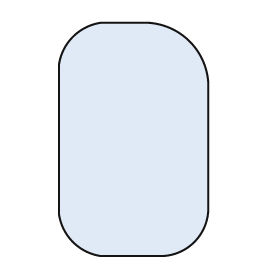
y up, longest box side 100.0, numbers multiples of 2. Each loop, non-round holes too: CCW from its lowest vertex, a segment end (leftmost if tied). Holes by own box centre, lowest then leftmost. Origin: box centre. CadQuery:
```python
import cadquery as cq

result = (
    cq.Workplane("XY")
    .moveTo(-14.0, -50.0)
    .lineTo(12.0, -50.0)
    .threePointArc((26.0, -44.0), (32.0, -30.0))
    .lineTo(32.0, 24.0)
    .threePointArc((24.0, 42.0), (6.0, 50.0))
    .lineTo(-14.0, 50.0)
    .threePointArc((-26.0, 44.0), (-32.0, 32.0))
    .lineTo(-32.0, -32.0)
    .threePointArc((-26.0, -44.0), (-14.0, -50.0))
    .close()
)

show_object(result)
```